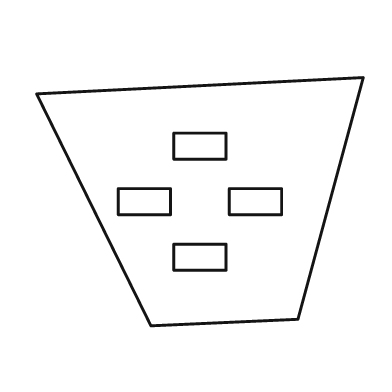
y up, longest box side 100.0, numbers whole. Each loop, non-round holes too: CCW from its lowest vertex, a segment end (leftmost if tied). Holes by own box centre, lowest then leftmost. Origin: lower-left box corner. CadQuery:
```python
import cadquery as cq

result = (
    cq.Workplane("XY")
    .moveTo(35.0, 0.0)
    .lineTo(80.0, 2.0)
    .lineTo(100.0, 76.0)
    .lineTo(0.0, 71.0)
    .close()
    .moveTo(42.0, 17.0)
    .lineTo(58.0, 17.0)
    .lineTo(58.0, 25.0)
    .lineTo(42.0, 25.0)
    .close()
    .moveTo(25.0, 34.0)
    .lineTo(41.0, 34.0)
    .lineTo(41.0, 42.0)
    .lineTo(25.0, 42.0)
    .close()
    .moveTo(59.0, 34.0)
    .lineTo(75.0, 34.0)
    .lineTo(75.0, 42.0)
    .lineTo(59.0, 42.0)
    .close()
    .moveTo(42.0, 51.0)
    .lineTo(58.0, 51.0)
    .lineTo(58.0, 59.0)
    .lineTo(42.0, 59.0)
    .close()
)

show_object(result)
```